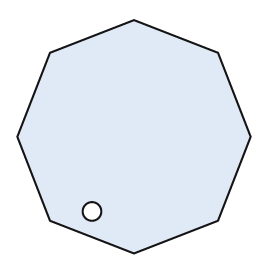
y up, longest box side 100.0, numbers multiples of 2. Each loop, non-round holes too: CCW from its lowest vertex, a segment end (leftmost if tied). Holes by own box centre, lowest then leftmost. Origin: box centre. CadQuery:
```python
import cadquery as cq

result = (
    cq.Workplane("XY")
    .moveTo(0.0, -50.0)
    .lineTo(36.0, -36.0)
    .lineTo(50.0, 0.0)
    .lineTo(36.0, 36.0)
    .lineTo(0.0, 50.0)
    .lineTo(-36.0, 36.0)
    .lineTo(-50.0, 0.0)
    .lineTo(-36.0, -36.0)
    .close()
    .moveTo(-18.0, -32.0)
    .circle(4.0)
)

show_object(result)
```